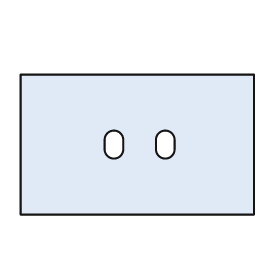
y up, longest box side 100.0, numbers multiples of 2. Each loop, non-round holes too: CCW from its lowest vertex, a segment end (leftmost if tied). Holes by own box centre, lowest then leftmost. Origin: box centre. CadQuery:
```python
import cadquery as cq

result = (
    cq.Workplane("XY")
    .moveTo(-50.0, -30.0)
    .lineTo(50.0, -30.0)
    .lineTo(50.0, 30.0)
    .lineTo(-50.0, 30.0)
    .close()
    .moveTo(-14.0, -2.0)
    .threePointArc((-10.0, -6.0), (-6.0, -2.0))
    .lineTo(-6.0, 2.0)
    .threePointArc((-10.0, 6.0), (-14.0, 2.0))
    .close()
    .moveTo(8.0, -2.0)
    .threePointArc((12.0, -6.0), (16.0, -2.0))
    .lineTo(16.0, 2.0)
    .threePointArc((12.0, 6.0), (8.0, 2.0))
    .close()
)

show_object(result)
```